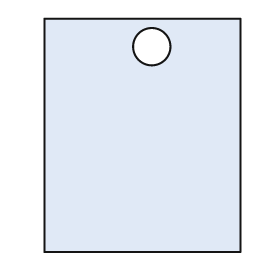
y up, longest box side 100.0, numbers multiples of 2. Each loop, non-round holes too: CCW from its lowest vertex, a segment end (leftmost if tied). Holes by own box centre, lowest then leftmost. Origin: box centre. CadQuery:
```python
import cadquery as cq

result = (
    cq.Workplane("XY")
    .moveTo(-42.0, -50.0)
    .lineTo(42.0, -50.0)
    .lineTo(42.0, 50.0)
    .lineTo(-42.0, 50.0)
    .close()
    .moveTo(4.0, 38.0)
    .circle(8.0)
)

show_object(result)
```